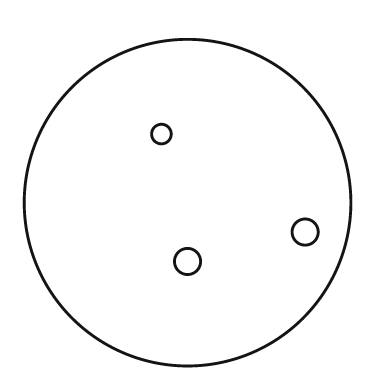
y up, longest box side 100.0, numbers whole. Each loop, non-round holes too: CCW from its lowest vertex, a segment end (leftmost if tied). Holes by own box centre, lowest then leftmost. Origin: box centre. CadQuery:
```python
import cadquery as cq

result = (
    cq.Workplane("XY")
    .moveTo(0.0, 0.0)
    .circle(50.0)
    .moveTo(0.0, -18.0)
    .circle(4.0)
    .moveTo(36.0, -9.0)
    .circle(4.0)
    .moveTo(-8.0, 21.0)
    .circle(3.0)
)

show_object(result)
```